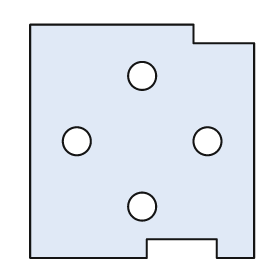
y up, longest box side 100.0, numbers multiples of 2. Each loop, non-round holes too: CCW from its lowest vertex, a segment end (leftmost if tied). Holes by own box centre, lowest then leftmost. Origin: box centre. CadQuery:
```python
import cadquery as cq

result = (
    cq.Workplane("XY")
    .moveTo(-48.0, -50.0)
    .lineTo(2.0, -50.0)
    .lineTo(2.0, -42.0)
    .lineTo(32.0, -42.0)
    .lineTo(32.0, -50.0)
    .lineTo(48.0, -50.0)
    .lineTo(48.0, 42.0)
    .lineTo(22.0, 42.0)
    .lineTo(22.0, 50.0)
    .lineTo(-48.0, 50.0)
    .close()
    .moveTo(0.0, -28.0)
    .circle(6.0)
    .moveTo(-28.0, 0.0)
    .circle(6.0)
    .moveTo(28.0, 0.0)
    .circle(6.0)
    .moveTo(0.0, 28.0)
    .circle(6.0)
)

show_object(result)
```